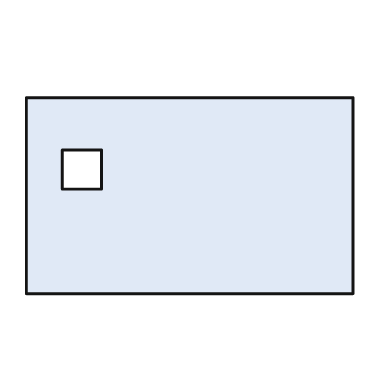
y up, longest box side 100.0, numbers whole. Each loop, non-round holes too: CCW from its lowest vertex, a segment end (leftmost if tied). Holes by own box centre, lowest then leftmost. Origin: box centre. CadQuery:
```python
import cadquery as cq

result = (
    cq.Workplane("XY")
    .moveTo(-50.0, -30.0)
    .lineTo(50.0, -30.0)
    .lineTo(50.0, 30.0)
    .lineTo(-50.0, 30.0)
    .close()
    .moveTo(-39.0, 2.0)
    .lineTo(-27.0, 2.0)
    .lineTo(-27.0, 14.0)
    .lineTo(-39.0, 14.0)
    .close()
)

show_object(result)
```